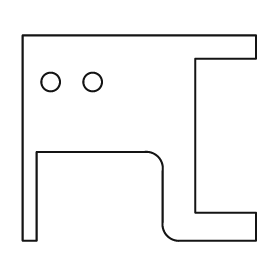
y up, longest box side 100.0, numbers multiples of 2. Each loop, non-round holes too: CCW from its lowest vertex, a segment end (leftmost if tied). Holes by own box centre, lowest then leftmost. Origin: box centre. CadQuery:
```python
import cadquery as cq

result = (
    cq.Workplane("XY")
    .moveTo(-50.0, -44.0)
    .lineTo(-44.0, -44.0)
    .lineTo(-44.0, -6.0)
    .lineTo(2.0, -6.0)
    .threePointArc((8.0, -8.0), (10.0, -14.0))
    .lineTo(10.0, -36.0)
    .threePointArc((12.0, -42.0), (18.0, -44.0))
    .lineTo(50.0, -44.0)
    .lineTo(50.0, -32.0)
    .lineTo(24.0, -32.0)
    .lineTo(24.0, 34.0)
    .lineTo(50.0, 34.0)
    .lineTo(50.0, 44.0)
    .lineTo(-50.0, 44.0)
    .close()
    .moveTo(-38.0, 24.0)
    .circle(4.0)
    .moveTo(-20.0, 24.0)
    .circle(4.0)
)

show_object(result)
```